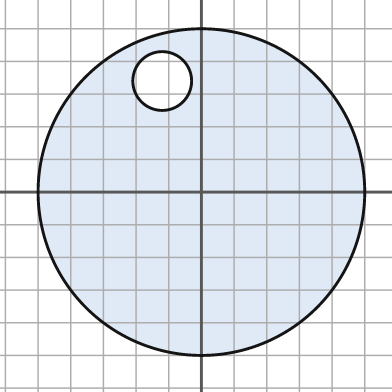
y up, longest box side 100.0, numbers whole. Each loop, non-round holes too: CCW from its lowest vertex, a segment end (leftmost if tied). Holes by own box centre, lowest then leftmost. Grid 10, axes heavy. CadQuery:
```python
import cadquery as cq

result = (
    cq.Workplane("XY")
    .moveTo(0.0, 0.0)
    .circle(50.0)
    .moveTo(-12.0, 34.0)
    .circle(9.0)
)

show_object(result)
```